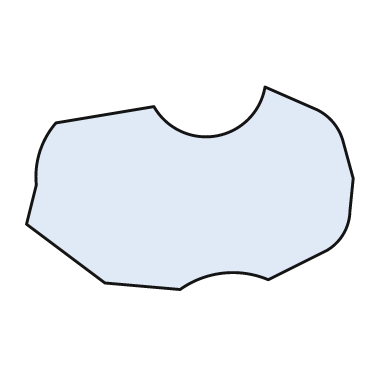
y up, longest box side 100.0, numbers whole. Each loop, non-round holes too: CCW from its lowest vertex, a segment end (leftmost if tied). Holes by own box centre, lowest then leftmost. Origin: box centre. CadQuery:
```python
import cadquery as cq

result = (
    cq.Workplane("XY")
    .moveTo(-3.0, -31.0)
    .threePointArc((10.0, -26.0), (24.0, -28.0))
    .lineTo(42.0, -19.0)
    .threePointArc((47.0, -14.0), (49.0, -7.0))
    .lineTo(50.0, 3.0)
    .lineTo(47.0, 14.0)
    .threePointArc((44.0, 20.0), (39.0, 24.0))
    .lineTo(23.0, 31.0)
    .threePointArc((8.0, 16.0), (-11.0, 25.0))
    .lineTo(-41.0, 20.0)
    .threePointArc((-46.0, 11.0), (-47.0, 1.0))
    .lineTo(-50.0, -11.0)
    .lineTo(-26.0, -29.0)
    .close()
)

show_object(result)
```